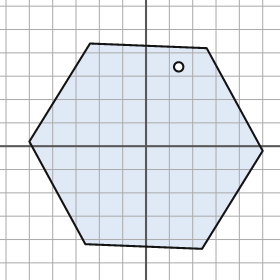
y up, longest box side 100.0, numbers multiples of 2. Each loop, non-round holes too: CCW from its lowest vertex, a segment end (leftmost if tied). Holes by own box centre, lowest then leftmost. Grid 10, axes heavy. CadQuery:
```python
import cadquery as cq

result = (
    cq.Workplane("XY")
    .moveTo(24.0, -44.0)
    .lineTo(50.0, -2.0)
    .lineTo(26.0, 42.0)
    .lineTo(-24.0, 44.0)
    .lineTo(-50.0, 2.0)
    .lineTo(-26.0, -42.0)
    .close()
    .moveTo(14.0, 34.0)
    .circle(2.0)
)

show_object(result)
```